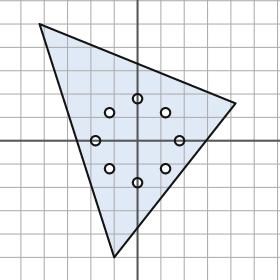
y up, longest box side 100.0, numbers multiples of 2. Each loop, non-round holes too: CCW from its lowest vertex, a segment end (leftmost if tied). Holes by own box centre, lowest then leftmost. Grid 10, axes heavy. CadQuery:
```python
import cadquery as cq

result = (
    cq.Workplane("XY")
    .moveTo(-10.0, -50.0)
    .lineTo(42.0, 16.0)
    .lineTo(-42.0, 50.0)
    .close()
    .moveTo(0.0, -18.0)
    .circle(2.0)
    .moveTo(-12.0, -12.0)
    .circle(2.0)
    .moveTo(12.0, -12.0)
    .circle(2.0)
    .moveTo(-18.0, 0.0)
    .circle(2.0)
    .moveTo(18.0, 0.0)
    .circle(2.0)
    .moveTo(-12.0, 12.0)
    .circle(2.0)
    .moveTo(12.0, 12.0)
    .circle(2.0)
    .moveTo(0.0, 18.0)
    .circle(2.0)
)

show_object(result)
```